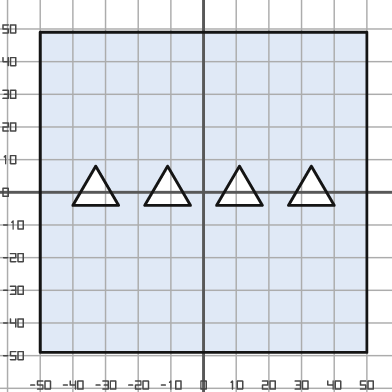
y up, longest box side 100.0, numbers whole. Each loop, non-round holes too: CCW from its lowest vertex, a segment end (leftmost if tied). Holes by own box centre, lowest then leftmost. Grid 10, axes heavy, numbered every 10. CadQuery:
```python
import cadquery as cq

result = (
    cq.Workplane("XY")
    .moveTo(-50.0, -49.0)
    .lineTo(50.0, -49.0)
    .lineTo(50.0, 49.0)
    .lineTo(-50.0, 49.0)
    .close()
    .moveTo(-40.0, -4.0)
    .lineTo(-26.0, -4.0)
    .lineTo(-33.0, 8.0)
    .close()
    .moveTo(-18.0, -4.0)
    .lineTo(-4.0, -4.0)
    .lineTo(-11.0, 8.0)
    .close()
    .moveTo(4.0, -4.0)
    .lineTo(18.0, -4.0)
    .lineTo(11.0, 8.0)
    .close()
    .moveTo(26.0, -4.0)
    .lineTo(40.0, -4.0)
    .lineTo(33.0, 8.0)
    .close()
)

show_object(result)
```